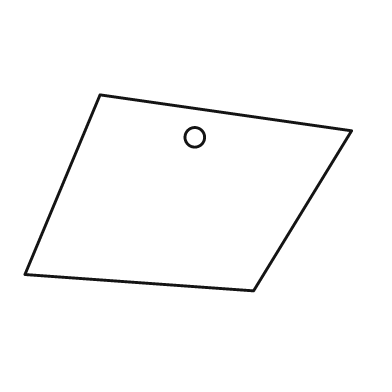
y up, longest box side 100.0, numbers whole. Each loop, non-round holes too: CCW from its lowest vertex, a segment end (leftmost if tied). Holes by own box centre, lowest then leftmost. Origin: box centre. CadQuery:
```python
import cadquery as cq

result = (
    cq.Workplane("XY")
    .moveTo(20.0, -30.0)
    .lineTo(50.0, 19.0)
    .lineTo(-27.0, 30.0)
    .lineTo(-50.0, -25.0)
    .close()
    .moveTo(2.0, 17.0)
    .circle(3.0)
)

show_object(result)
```